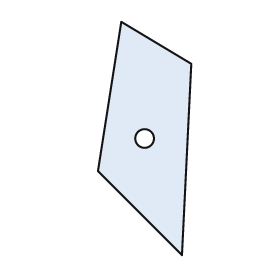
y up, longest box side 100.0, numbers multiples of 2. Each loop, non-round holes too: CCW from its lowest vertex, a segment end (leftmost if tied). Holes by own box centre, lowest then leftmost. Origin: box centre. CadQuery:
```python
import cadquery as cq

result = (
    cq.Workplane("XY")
    .moveTo(16.0, -50.0)
    .lineTo(20.0, 32.0)
    .lineTo(-10.0, 50.0)
    .lineTo(-20.0, -14.0)
    .close()
    .moveTo(0.0, 0.0)
    .circle(4.0)
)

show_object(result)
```